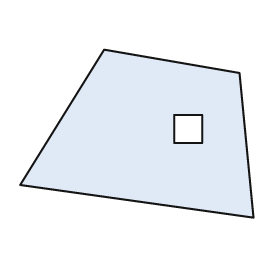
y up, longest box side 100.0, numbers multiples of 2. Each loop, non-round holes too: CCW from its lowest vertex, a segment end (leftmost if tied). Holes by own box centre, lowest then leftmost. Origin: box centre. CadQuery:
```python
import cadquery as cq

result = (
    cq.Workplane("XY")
    .moveTo(50.0, -36.0)
    .lineTo(44.0, 26.0)
    .lineTo(-14.0, 36.0)
    .lineTo(-50.0, -22.0)
    .close()
    .moveTo(16.0, -4.0)
    .lineTo(28.0, -4.0)
    .lineTo(28.0, 8.0)
    .lineTo(16.0, 8.0)
    .close()
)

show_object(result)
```